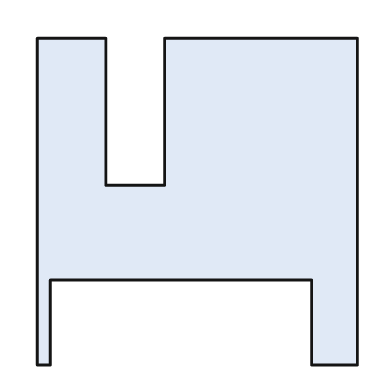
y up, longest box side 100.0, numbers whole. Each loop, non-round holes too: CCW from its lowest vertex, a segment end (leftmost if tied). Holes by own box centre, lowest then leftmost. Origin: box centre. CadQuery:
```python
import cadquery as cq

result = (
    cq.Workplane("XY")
    .moveTo(-49.0, -50.0)
    .lineTo(-45.0, -50.0)
    .lineTo(-45.0, -24.0)
    .lineTo(35.0, -24.0)
    .lineTo(35.0, -50.0)
    .lineTo(49.0, -50.0)
    .lineTo(49.0, 50.0)
    .lineTo(-10.0, 50.0)
    .lineTo(-10.0, 5.0)
    .lineTo(-28.0, 5.0)
    .lineTo(-28.0, 50.0)
    .lineTo(-49.0, 50.0)
    .close()
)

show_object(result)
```